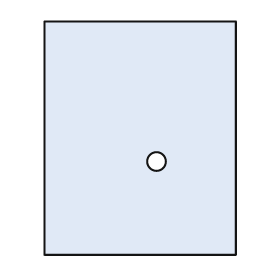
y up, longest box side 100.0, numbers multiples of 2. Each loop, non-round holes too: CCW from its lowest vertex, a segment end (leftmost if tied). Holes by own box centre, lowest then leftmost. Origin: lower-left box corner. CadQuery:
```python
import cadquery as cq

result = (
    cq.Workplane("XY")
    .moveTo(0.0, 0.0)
    .lineTo(82.0, 0.0)
    .lineTo(82.0, 100.0)
    .lineTo(0.0, 100.0)
    .close()
    .moveTo(48.0, 40.0)
    .circle(4.0)
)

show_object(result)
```